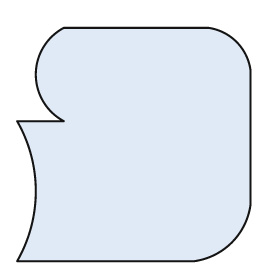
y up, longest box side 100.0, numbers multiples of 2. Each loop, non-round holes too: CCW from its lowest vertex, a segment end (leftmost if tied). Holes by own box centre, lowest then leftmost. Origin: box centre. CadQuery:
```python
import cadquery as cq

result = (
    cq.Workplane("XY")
    .moveTo(-50.0, -50.0)
    .lineTo(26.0, -50.0)
    .threePointArc((42.0, -42.0), (50.0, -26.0))
    .lineTo(50.0, 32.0)
    .threePointArc((44.0, 44.0), (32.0, 50.0))
    .lineTo(-30.0, 50.0)
    .threePointArc((-42.0, 30.0), (-30.0, 10.0))
    .lineTo(-50.0, 10.0)
    .threePointArc((-42.0, -20.0), (-50.0, -50.0))
    .close()
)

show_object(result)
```